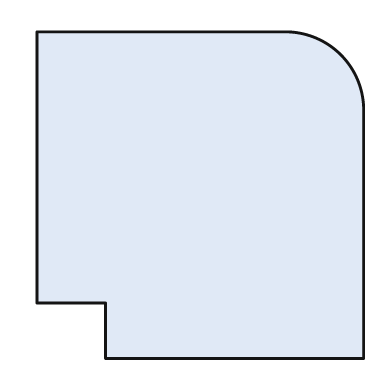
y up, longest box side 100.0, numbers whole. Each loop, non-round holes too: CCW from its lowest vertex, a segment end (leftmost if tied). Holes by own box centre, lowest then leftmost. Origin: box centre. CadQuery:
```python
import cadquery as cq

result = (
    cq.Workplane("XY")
    .moveTo(-29.0, -50.0)
    .lineTo(50.0, -50.0)
    .lineTo(50.0, 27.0)
    .threePointArc((43.0, 43.0), (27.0, 50.0))
    .lineTo(-50.0, 50.0)
    .lineTo(-50.0, -33.0)
    .lineTo(-29.0, -33.0)
    .close()
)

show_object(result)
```